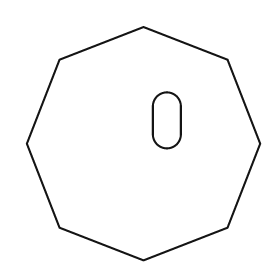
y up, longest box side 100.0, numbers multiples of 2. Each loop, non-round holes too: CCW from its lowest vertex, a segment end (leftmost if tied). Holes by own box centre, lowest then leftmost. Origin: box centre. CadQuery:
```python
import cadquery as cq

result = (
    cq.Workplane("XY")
    .moveTo(0.0, -50.0)
    .lineTo(36.0, -36.0)
    .lineTo(50.0, 0.0)
    .lineTo(36.0, 36.0)
    .lineTo(0.0, 50.0)
    .lineTo(-36.0, 36.0)
    .lineTo(-50.0, 0.0)
    .lineTo(-36.0, -36.0)
    .close()
    .moveTo(4.0, 4.0)
    .threePointArc((10.0, -2.0), (16.0, 4.0))
    .lineTo(16.0, 16.0)
    .threePointArc((10.0, 22.0), (4.0, 16.0))
    .close()
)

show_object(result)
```